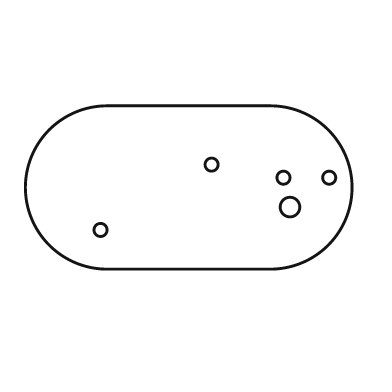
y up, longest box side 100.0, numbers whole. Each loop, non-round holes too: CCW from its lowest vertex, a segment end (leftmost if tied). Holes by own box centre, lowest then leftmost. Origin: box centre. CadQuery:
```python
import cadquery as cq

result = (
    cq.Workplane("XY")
    .moveTo(-25.0, -25.0)
    .lineTo(25.0, -25.0)
    .threePointArc((50.0, 0.0), (25.0, 25.0))
    .lineTo(-25.0, 25.0)
    .threePointArc((-50.0, 0.0), (-25.0, -25.0))
    .close()
    .moveTo(-27.0, -13.0)
    .circle(2.0)
    .moveTo(31.0, -6.0)
    .circle(3.0)
    .moveTo(29.0, 3.0)
    .circle(2.0)
    .moveTo(43.0, 3.0)
    .circle(2.0)
    .moveTo(7.0, 7.0)
    .circle(2.0)
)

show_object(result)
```